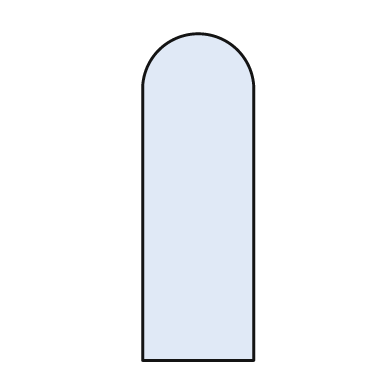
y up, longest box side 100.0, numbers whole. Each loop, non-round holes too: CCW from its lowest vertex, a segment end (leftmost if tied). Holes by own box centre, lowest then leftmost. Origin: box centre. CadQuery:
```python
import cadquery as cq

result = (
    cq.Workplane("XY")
    .moveTo(-17.0, -50.0)
    .lineTo(17.0, -50.0)
    .lineTo(17.0, 34.0)
    .threePointArc((0.0, 50.0), (-17.0, 34.0))
    .close()
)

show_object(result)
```